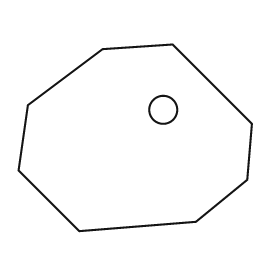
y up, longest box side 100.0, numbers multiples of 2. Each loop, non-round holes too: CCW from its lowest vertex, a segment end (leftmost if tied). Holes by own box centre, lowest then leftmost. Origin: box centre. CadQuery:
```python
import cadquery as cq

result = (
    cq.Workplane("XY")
    .moveTo(-24.0, -40.0)
    .lineTo(26.0, -36.0)
    .lineTo(48.0, -18.0)
    .lineTo(50.0, 6.0)
    .lineTo(16.0, 40.0)
    .lineTo(-14.0, 38.0)
    .lineTo(-46.0, 14.0)
    .lineTo(-50.0, -14.0)
    .close()
    .moveTo(12.0, 12.0)
    .circle(6.0)
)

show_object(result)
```